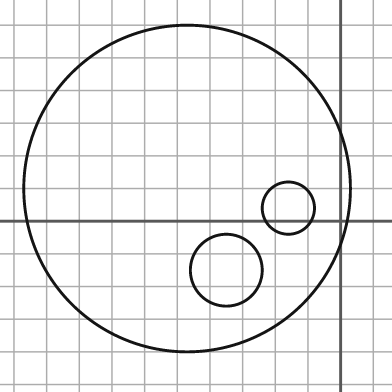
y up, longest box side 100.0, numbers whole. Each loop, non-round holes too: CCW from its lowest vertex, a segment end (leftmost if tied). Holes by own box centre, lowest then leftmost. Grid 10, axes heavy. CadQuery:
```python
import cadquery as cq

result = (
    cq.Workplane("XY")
    .moveTo(-47.0, 10.0)
    .circle(50.0)
    .moveTo(-35.0, -15.0)
    .circle(11.0)
    .moveTo(-16.0, 4.0)
    .circle(8.0)
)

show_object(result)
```